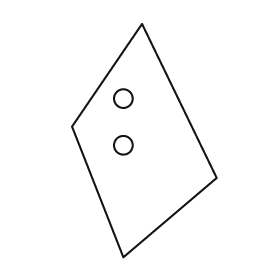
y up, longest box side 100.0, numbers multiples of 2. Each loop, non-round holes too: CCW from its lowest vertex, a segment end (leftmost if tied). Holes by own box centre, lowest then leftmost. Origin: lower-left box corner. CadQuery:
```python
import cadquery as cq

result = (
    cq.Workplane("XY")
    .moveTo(22.0, 0.0)
    .lineTo(62.0, 34.0)
    .lineTo(30.0, 100.0)
    .lineTo(0.0, 56.0)
    .close()
    .moveTo(22.0, 48.0)
    .circle(4.0)
    .moveTo(22.0, 68.0)
    .circle(4.0)
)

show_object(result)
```